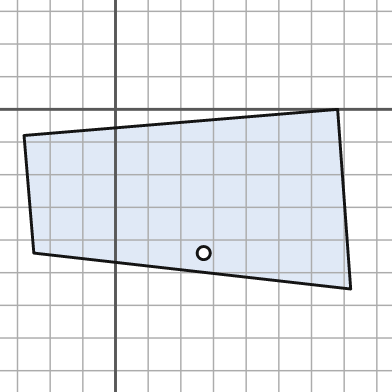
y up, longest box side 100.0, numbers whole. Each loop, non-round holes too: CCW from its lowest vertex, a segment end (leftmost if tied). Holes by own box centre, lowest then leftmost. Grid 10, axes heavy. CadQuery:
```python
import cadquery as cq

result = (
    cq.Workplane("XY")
    .moveTo(72.0, -55.0)
    .lineTo(68.0, 0.0)
    .lineTo(-28.0, -8.0)
    .lineTo(-25.0, -44.0)
    .close()
    .moveTo(27.0, -44.0)
    .circle(2.0)
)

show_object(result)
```